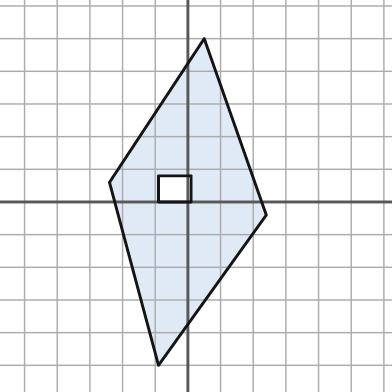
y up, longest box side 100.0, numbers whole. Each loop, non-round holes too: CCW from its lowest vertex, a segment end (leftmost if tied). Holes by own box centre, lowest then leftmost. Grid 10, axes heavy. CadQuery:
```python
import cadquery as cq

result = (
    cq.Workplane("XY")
    .moveTo(-9.0, -50.0)
    .lineTo(24.0, -4.0)
    .lineTo(5.0, 50.0)
    .lineTo(-24.0, 6.0)
    .close()
    .moveTo(-9.0, 0.0)
    .lineTo(1.0, 0.0)
    .lineTo(1.0, 8.0)
    .lineTo(-9.0, 8.0)
    .close()
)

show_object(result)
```